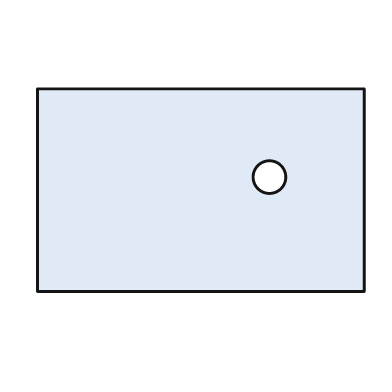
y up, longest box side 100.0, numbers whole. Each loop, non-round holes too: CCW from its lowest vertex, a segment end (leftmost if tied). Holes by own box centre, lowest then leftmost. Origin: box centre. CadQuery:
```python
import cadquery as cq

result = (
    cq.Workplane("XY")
    .moveTo(-50.0, -31.0)
    .lineTo(50.0, -31.0)
    .lineTo(50.0, 31.0)
    .lineTo(-50.0, 31.0)
    .close()
    .moveTo(21.0, 4.0)
    .circle(5.0)
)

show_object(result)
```